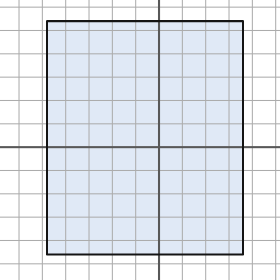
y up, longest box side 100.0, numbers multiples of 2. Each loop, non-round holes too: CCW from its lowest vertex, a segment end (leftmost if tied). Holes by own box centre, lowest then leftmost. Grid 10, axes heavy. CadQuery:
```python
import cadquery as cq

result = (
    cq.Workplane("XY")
    .moveTo(-48.0, -46.0)
    .lineTo(36.0, -46.0)
    .lineTo(36.0, 54.0)
    .lineTo(-48.0, 54.0)
    .close()
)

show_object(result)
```